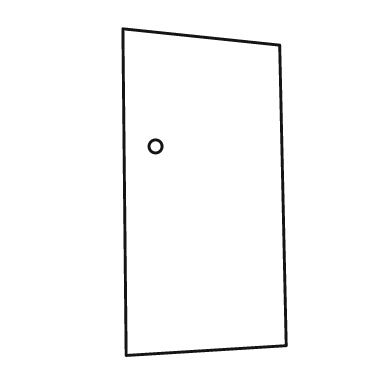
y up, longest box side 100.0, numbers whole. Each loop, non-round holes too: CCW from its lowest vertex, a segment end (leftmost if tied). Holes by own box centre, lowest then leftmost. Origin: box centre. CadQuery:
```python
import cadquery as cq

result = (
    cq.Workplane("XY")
    .moveTo(-24.0, -50.0)
    .lineTo(25.0, -47.0)
    .lineTo(23.0, 45.0)
    .lineTo(-25.0, 50.0)
    .close()
    .moveTo(-15.0, 14.0)
    .circle(2.0)
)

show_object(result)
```